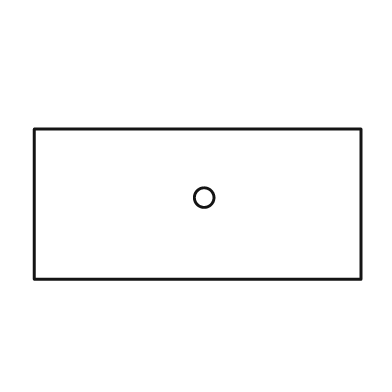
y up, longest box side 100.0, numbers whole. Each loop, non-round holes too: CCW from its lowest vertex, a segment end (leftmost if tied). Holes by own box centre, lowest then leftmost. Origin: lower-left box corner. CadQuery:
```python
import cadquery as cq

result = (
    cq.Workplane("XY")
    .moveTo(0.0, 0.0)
    .lineTo(100.0, 0.0)
    .lineTo(100.0, 46.0)
    .lineTo(0.0, 46.0)
    .close()
    .moveTo(52.0, 25.0)
    .circle(3.0)
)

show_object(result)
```